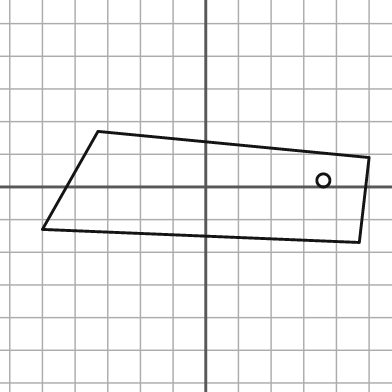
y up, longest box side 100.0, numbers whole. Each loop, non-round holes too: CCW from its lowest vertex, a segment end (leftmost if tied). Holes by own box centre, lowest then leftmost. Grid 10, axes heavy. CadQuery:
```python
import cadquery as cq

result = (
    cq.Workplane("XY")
    .moveTo(47.0, -17.0)
    .lineTo(50.0, 9.0)
    .lineTo(-33.0, 17.0)
    .lineTo(-50.0, -13.0)
    .close()
    .moveTo(36.0, 2.0)
    .circle(2.0)
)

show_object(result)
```